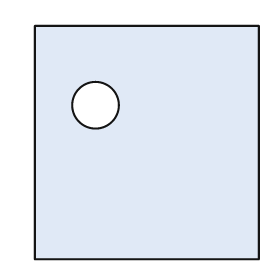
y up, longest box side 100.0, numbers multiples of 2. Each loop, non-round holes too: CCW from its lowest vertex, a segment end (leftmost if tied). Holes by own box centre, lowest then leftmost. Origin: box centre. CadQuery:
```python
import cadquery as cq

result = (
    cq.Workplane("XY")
    .moveTo(-48.0, -50.0)
    .lineTo(48.0, -50.0)
    .lineTo(48.0, 50.0)
    .lineTo(-48.0, 50.0)
    .close()
    .moveTo(-22.0, 16.0)
    .circle(10.0)
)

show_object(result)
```